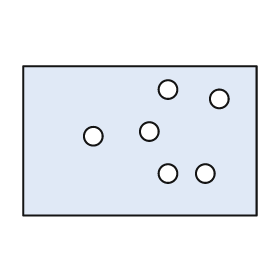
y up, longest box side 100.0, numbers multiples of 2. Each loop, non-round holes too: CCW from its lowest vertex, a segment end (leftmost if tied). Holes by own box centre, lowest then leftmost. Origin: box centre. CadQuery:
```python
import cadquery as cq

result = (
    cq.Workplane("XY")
    .moveTo(-50.0, -32.0)
    .lineTo(50.0, -32.0)
    .lineTo(50.0, 32.0)
    .lineTo(-50.0, 32.0)
    .close()
    .moveTo(12.0, -14.0)
    .circle(4.0)
    .moveTo(28.0, -14.0)
    .circle(4.0)
    .moveTo(-20.0, 2.0)
    .circle(4.0)
    .moveTo(4.0, 4.0)
    .circle(4.0)
    .moveTo(34.0, 18.0)
    .circle(4.0)
    .moveTo(12.0, 22.0)
    .circle(4.0)
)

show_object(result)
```